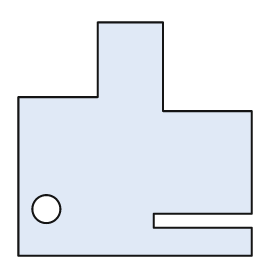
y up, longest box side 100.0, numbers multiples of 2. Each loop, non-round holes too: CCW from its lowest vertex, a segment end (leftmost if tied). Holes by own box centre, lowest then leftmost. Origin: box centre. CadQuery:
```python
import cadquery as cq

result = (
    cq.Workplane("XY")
    .moveTo(-50.0, -50.0)
    .lineTo(50.0, -50.0)
    .lineTo(50.0, -38.0)
    .lineTo(8.0, -38.0)
    .lineTo(8.0, -32.0)
    .lineTo(50.0, -32.0)
    .lineTo(50.0, 12.0)
    .lineTo(12.0, 12.0)
    .lineTo(12.0, 50.0)
    .lineTo(-16.0, 50.0)
    .lineTo(-16.0, 18.0)
    .lineTo(-50.0, 18.0)
    .close()
    .moveTo(-38.0, -30.0)
    .circle(6.0)
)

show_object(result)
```